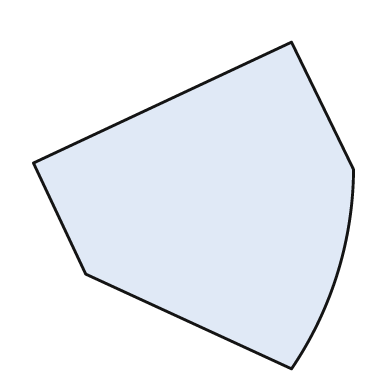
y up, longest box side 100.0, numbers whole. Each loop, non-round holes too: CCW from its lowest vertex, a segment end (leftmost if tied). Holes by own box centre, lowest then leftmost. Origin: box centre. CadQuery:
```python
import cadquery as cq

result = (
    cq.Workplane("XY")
    .moveTo(30.0, -50.0)
    .threePointArc((44.0, -21.0), (49.0, 11.0))
    .lineTo(30.0, 50.0)
    .lineTo(-49.0, 13.0)
    .lineTo(-33.0, -21.0)
    .close()
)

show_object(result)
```